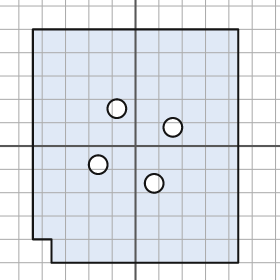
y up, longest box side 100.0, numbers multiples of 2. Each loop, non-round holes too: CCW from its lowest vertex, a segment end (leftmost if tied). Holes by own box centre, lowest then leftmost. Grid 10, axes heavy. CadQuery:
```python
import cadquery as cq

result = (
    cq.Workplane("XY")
    .moveTo(-36.0, -50.0)
    .lineTo(44.0, -50.0)
    .lineTo(44.0, 50.0)
    .lineTo(-44.0, 50.0)
    .lineTo(-44.0, -40.0)
    .lineTo(-36.0, -40.0)
    .close()
    .moveTo(8.0, -16.0)
    .circle(4.0)
    .moveTo(-16.0, -8.0)
    .circle(4.0)
    .moveTo(16.0, 8.0)
    .circle(4.0)
    .moveTo(-8.0, 16.0)
    .circle(4.0)
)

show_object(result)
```